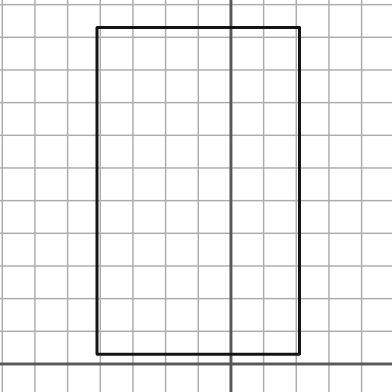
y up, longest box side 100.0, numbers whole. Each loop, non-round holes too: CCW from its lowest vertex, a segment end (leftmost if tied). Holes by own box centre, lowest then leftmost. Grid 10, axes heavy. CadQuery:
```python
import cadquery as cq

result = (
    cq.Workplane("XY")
    .moveTo(-41.0, 3.0)
    .lineTo(21.0, 3.0)
    .lineTo(21.0, 103.0)
    .lineTo(-41.0, 103.0)
    .close()
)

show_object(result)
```